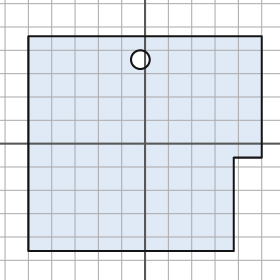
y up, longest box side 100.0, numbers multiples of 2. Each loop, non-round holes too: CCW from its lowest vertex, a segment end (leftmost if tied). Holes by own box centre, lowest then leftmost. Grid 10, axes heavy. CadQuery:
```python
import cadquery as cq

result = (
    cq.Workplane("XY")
    .moveTo(-50.0, -46.0)
    .lineTo(38.0, -46.0)
    .lineTo(38.0, -6.0)
    .lineTo(50.0, -6.0)
    .lineTo(50.0, 46.0)
    .lineTo(-50.0, 46.0)
    .close()
    .moveTo(-2.0, 36.0)
    .circle(4.0)
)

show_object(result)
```